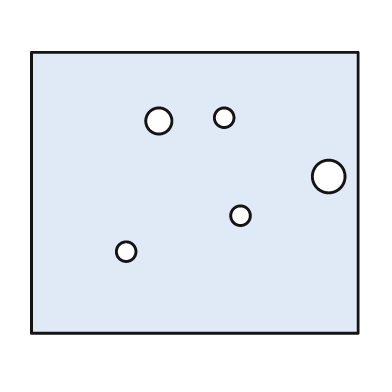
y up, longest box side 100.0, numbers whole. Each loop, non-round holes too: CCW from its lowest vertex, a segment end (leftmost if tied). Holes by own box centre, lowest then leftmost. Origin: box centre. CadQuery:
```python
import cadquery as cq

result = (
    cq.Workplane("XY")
    .moveTo(-50.0, -43.0)
    .lineTo(50.0, -43.0)
    .lineTo(50.0, 43.0)
    .lineTo(-50.0, 43.0)
    .close()
    .moveTo(-21.0, -18.0)
    .circle(3.0)
    .moveTo(14.0, -7.0)
    .circle(3.0)
    .moveTo(41.0, 5.0)
    .circle(5.0)
    .moveTo(-11.0, 22.0)
    .circle(4.0)
    .moveTo(9.0, 23.0)
    .circle(3.0)
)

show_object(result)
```